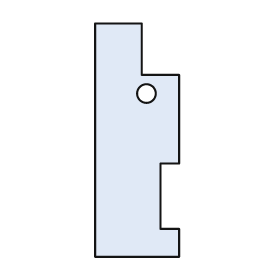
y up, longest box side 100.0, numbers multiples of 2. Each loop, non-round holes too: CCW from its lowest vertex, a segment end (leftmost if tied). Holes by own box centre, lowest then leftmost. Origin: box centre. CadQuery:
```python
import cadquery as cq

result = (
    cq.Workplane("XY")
    .moveTo(-18.0, -50.0)
    .lineTo(18.0, -50.0)
    .lineTo(18.0, -38.0)
    .lineTo(10.0, -38.0)
    .lineTo(10.0, -10.0)
    .lineTo(18.0, -10.0)
    .lineTo(18.0, 28.0)
    .lineTo(2.0, 28.0)
    .lineTo(2.0, 50.0)
    .lineTo(-18.0, 50.0)
    .close()
    .moveTo(4.0, 20.0)
    .circle(4.0)
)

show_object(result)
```